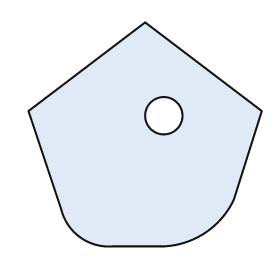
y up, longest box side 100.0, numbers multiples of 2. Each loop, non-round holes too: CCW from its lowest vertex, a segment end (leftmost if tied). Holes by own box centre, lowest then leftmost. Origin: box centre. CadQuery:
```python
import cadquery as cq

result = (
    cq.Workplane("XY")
    .moveTo(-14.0, -48.0)
    .lineTo(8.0, -48.0)
    .threePointArc((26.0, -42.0), (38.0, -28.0))
    .lineTo(50.0, 10.0)
    .lineTo(0.0, 48.0)
    .lineTo(-50.0, 10.0)
    .lineTo(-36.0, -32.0)
    .threePointArc((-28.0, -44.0), (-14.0, -48.0))
    .close()
    .moveTo(8.0, 8.0)
    .circle(8.0)
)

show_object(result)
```